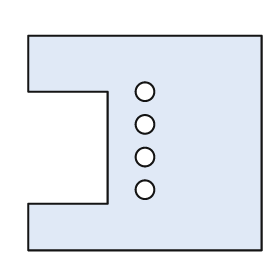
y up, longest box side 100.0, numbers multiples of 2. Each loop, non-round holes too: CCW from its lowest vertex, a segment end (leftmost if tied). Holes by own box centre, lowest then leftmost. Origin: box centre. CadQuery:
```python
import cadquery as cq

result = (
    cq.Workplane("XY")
    .moveTo(-50.0, -46.0)
    .lineTo(50.0, -46.0)
    .lineTo(50.0, 46.0)
    .lineTo(-50.0, 46.0)
    .lineTo(-50.0, 22.0)
    .lineTo(-16.0, 22.0)
    .lineTo(-16.0, -26.0)
    .lineTo(-50.0, -26.0)
    .close()
    .moveTo(0.0, -20.0)
    .circle(4.0)
    .moveTo(0.0, -6.0)
    .circle(4.0)
    .moveTo(0.0, 8.0)
    .circle(4.0)
    .moveTo(0.0, 22.0)
    .circle(4.0)
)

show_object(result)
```